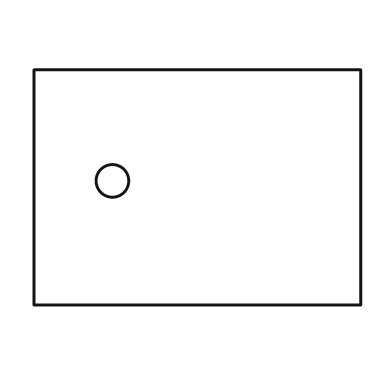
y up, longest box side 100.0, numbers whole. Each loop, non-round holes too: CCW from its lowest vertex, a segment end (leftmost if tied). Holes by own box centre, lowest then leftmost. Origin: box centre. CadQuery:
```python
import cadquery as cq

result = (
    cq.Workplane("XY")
    .moveTo(-50.0, -36.0)
    .lineTo(50.0, -36.0)
    .lineTo(50.0, 36.0)
    .lineTo(-50.0, 36.0)
    .close()
    .moveTo(-26.0, 2.0)
    .circle(5.0)
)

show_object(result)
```